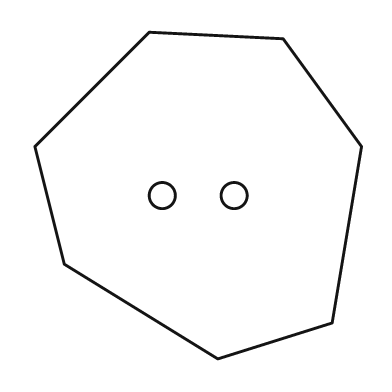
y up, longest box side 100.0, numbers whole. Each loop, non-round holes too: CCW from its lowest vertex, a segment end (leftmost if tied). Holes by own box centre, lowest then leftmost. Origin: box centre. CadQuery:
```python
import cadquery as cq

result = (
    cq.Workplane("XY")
    .moveTo(6.0, -50.0)
    .lineTo(41.0, -39.0)
    .lineTo(50.0, 15.0)
    .lineTo(26.0, 48.0)
    .lineTo(-15.0, 50.0)
    .lineTo(-50.0, 15.0)
    .lineTo(-41.0, -21.0)
    .close()
    .moveTo(-11.0, 0.0)
    .circle(4.0)
    .moveTo(11.0, 0.0)
    .circle(4.0)
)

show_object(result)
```